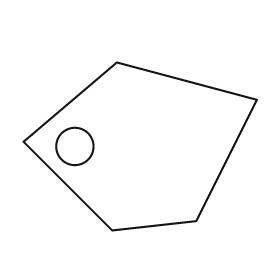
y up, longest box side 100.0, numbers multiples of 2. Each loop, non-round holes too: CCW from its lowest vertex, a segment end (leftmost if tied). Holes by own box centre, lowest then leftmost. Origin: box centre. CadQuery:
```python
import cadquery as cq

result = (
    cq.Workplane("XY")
    .moveTo(-12.0, -36.0)
    .lineTo(24.0, -32.0)
    .lineTo(50.0, 20.0)
    .lineTo(-10.0, 36.0)
    .lineTo(-50.0, 2.0)
    .close()
    .moveTo(-28.0, 0.0)
    .circle(8.0)
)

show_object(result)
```